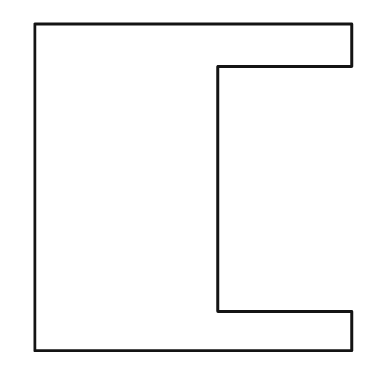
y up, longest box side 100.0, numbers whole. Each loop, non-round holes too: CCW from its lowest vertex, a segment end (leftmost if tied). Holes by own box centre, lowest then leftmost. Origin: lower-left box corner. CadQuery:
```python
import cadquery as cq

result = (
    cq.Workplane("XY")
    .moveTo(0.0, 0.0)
    .lineTo(97.0, 0.0)
    .lineTo(97.0, 12.0)
    .lineTo(56.0, 12.0)
    .lineTo(56.0, 87.0)
    .lineTo(97.0, 87.0)
    .lineTo(97.0, 100.0)
    .lineTo(0.0, 100.0)
    .close()
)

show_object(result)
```